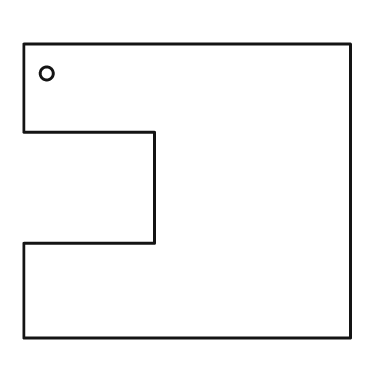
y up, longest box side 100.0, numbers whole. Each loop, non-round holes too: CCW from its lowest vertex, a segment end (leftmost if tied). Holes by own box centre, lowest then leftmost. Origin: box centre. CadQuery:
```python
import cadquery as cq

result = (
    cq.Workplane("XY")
    .moveTo(-50.0, -45.0)
    .lineTo(50.0, -45.0)
    .lineTo(50.0, 45.0)
    .lineTo(-50.0, 45.0)
    .lineTo(-50.0, 18.0)
    .lineTo(-10.0, 18.0)
    .lineTo(-10.0, -16.0)
    .lineTo(-50.0, -16.0)
    .close()
    .moveTo(-43.0, 36.0)
    .circle(2.0)
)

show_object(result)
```